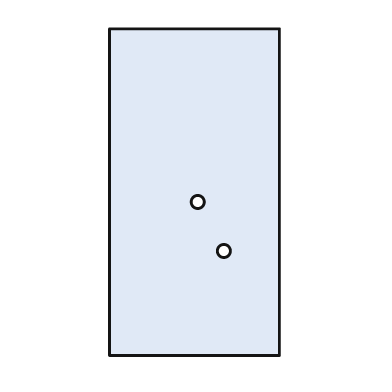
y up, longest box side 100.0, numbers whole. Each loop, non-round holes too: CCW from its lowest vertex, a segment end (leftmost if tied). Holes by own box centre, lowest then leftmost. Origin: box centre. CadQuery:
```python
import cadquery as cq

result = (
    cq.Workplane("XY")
    .moveTo(-26.0, -50.0)
    .lineTo(26.0, -50.0)
    .lineTo(26.0, 50.0)
    .lineTo(-26.0, 50.0)
    .close()
    .moveTo(9.0, -18.0)
    .circle(2.0)
    .moveTo(1.0, -3.0)
    .circle(2.0)
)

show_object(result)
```